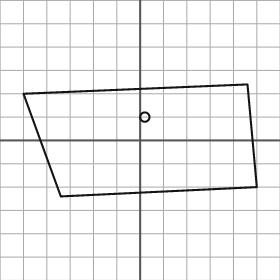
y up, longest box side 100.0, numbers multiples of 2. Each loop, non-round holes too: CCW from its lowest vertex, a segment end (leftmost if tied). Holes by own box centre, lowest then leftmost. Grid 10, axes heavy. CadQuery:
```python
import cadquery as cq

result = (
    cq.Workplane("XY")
    .moveTo(-34.0, -24.0)
    .lineTo(50.0, -20.0)
    .lineTo(46.0, 24.0)
    .lineTo(-50.0, 20.0)
    .close()
    .moveTo(2.0, 10.0)
    .circle(2.0)
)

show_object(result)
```